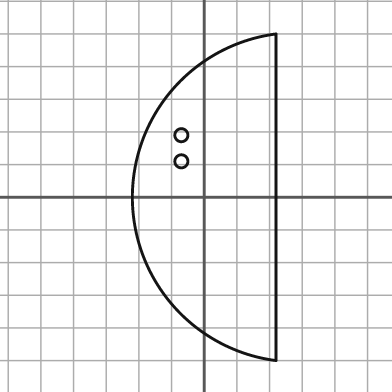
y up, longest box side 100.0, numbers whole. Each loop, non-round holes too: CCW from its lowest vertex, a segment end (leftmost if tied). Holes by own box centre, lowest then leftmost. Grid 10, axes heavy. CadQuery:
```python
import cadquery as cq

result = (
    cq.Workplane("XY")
    .moveTo(22.0, -50.0)
    .lineTo(22.0, 50.0)
    .threePointArc((-22.0, 0.0), (22.0, -50.0))
    .close()
    .moveTo(-7.0, 11.0)
    .circle(2.0)
    .moveTo(-7.0, 19.0)
    .circle(2.0)
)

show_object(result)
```